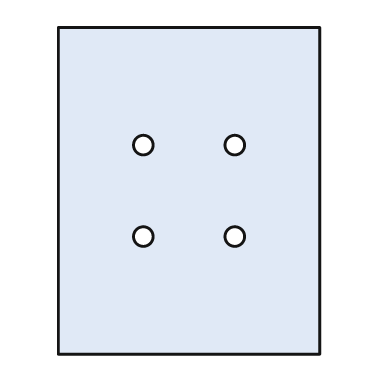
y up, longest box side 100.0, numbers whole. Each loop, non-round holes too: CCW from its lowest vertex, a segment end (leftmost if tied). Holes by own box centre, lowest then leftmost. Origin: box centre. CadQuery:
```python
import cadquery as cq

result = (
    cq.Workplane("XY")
    .moveTo(-40.0, -50.0)
    .lineTo(40.0, -50.0)
    .lineTo(40.0, 50.0)
    .lineTo(-40.0, 50.0)
    .close()
    .moveTo(-14.0, -14.0)
    .circle(3.0)
    .moveTo(14.0, -14.0)
    .circle(3.0)
    .moveTo(-14.0, 14.0)
    .circle(3.0)
    .moveTo(14.0, 14.0)
    .circle(3.0)
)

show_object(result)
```